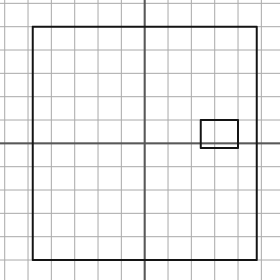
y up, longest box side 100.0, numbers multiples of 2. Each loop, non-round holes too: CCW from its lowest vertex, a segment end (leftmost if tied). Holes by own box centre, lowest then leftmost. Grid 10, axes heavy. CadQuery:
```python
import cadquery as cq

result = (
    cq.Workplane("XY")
    .moveTo(-48.0, -50.0)
    .lineTo(48.0, -50.0)
    .lineTo(48.0, 50.0)
    .lineTo(-48.0, 50.0)
    .close()
    .moveTo(24.0, -2.0)
    .lineTo(40.0, -2.0)
    .lineTo(40.0, 10.0)
    .lineTo(24.0, 10.0)
    .close()
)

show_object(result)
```